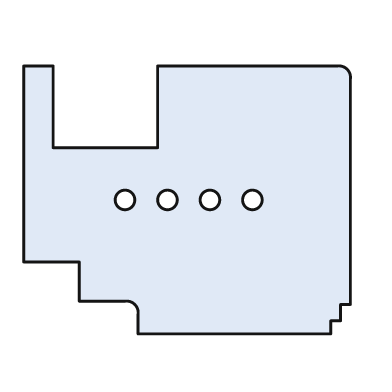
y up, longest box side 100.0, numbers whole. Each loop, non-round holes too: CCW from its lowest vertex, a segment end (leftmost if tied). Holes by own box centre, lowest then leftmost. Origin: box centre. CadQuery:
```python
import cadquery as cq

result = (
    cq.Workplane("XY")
    .moveTo(-15.0, -41.0)
    .lineTo(44.0, -41.0)
    .lineTo(44.0, -37.0)
    .lineTo(47.0, -37.0)
    .lineTo(47.0, -32.0)
    .lineTo(50.0, -32.0)
    .lineTo(50.0, 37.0)
    .threePointArc((49.0, 40.0), (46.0, 41.0))
    .lineTo(-9.0, 41.0)
    .lineTo(-9.0, 16.0)
    .lineTo(-41.0, 16.0)
    .lineTo(-41.0, 41.0)
    .lineTo(-50.0, 41.0)
    .lineTo(-50.0, -19.0)
    .lineTo(-33.0, -19.0)
    .lineTo(-33.0, -31.0)
    .lineTo(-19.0, -31.0)
    .threePointArc((-16.0, -32.0), (-15.0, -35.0))
    .close()
    .moveTo(-19.0, 0.0)
    .circle(3.0)
    .moveTo(-6.0, 0.0)
    .circle(3.0)
    .moveTo(7.0, 0.0)
    .circle(3.0)
    .moveTo(20.0, 0.0)
    .circle(3.0)
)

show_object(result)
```